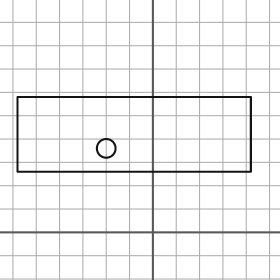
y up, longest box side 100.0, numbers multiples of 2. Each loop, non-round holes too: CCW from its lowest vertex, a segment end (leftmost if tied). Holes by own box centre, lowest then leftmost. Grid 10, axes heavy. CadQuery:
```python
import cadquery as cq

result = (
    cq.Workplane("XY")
    .moveTo(-58.0, 26.0)
    .lineTo(42.0, 26.0)
    .lineTo(42.0, 58.0)
    .lineTo(-58.0, 58.0)
    .close()
    .moveTo(-20.0, 36.0)
    .circle(4.0)
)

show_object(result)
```